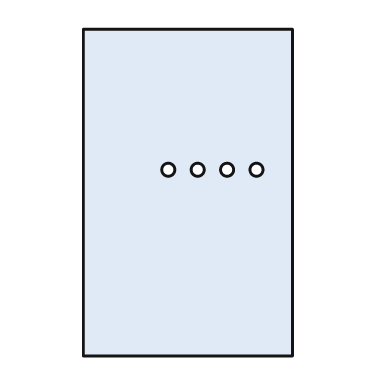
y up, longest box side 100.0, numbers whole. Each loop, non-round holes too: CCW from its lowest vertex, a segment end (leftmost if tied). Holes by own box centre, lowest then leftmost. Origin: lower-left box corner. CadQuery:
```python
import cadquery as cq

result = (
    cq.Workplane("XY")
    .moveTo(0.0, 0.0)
    .lineTo(64.0, 0.0)
    .lineTo(64.0, 100.0)
    .lineTo(0.0, 100.0)
    .close()
    .moveTo(26.0, 57.0)
    .circle(2.0)
    .moveTo(35.0, 57.0)
    .circle(2.0)
    .moveTo(44.0, 57.0)
    .circle(2.0)
    .moveTo(53.0, 57.0)
    .circle(2.0)
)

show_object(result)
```